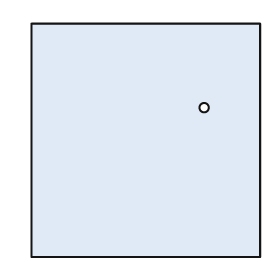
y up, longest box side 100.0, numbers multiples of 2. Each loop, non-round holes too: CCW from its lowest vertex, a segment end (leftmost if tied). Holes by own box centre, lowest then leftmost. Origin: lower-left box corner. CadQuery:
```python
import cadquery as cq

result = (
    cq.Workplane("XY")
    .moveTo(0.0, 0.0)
    .lineTo(98.0, 0.0)
    .lineTo(98.0, 100.0)
    .lineTo(0.0, 100.0)
    .close()
    .moveTo(74.0, 64.0)
    .circle(2.0)
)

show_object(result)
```